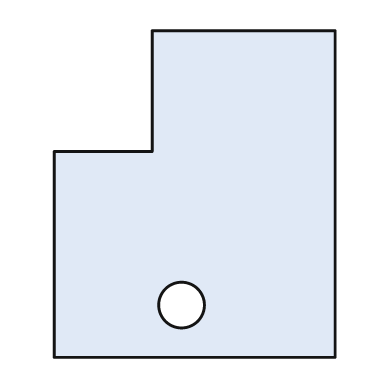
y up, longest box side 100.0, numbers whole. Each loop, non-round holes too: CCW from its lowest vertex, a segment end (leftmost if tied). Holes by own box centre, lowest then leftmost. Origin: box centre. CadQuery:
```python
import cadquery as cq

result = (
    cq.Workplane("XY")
    .moveTo(-43.0, -50.0)
    .lineTo(43.0, -50.0)
    .lineTo(43.0, 50.0)
    .lineTo(-13.0, 50.0)
    .lineTo(-13.0, 13.0)
    .lineTo(-43.0, 13.0)
    .close()
    .moveTo(-4.0, -34.0)
    .circle(7.0)
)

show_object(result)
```